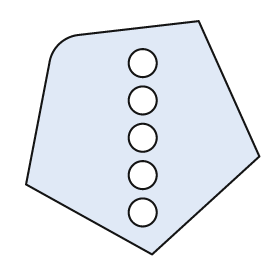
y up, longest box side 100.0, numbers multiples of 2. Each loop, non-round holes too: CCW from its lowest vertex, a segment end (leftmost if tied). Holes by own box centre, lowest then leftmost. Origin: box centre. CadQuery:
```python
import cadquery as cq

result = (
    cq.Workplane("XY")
    .moveTo(4.0, -50.0)
    .lineTo(50.0, -8.0)
    .lineTo(24.0, 50.0)
    .lineTo(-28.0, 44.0)
    .threePointArc((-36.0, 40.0), (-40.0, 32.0))
    .lineTo(-50.0, -20.0)
    .close()
    .moveTo(0.0, -32.0)
    .circle(6.0)
    .moveTo(0.0, -16.0)
    .circle(6.0)
    .moveTo(0.0, 0.0)
    .circle(6.0)
    .moveTo(0.0, 16.0)
    .circle(6.0)
    .moveTo(0.0, 32.0)
    .circle(6.0)
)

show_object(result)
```